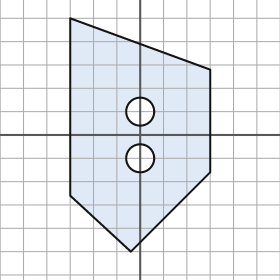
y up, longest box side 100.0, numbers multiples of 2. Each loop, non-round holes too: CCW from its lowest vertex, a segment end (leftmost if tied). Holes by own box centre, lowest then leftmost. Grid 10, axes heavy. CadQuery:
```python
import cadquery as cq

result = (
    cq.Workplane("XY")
    .moveTo(-4.0, -50.0)
    .lineTo(30.0, -16.0)
    .lineTo(30.0, 28.0)
    .lineTo(-30.0, 50.0)
    .lineTo(-30.0, -26.0)
    .close()
    .moveTo(0.0, -10.0)
    .circle(6.0)
    .moveTo(0.0, 10.0)
    .circle(6.0)
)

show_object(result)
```